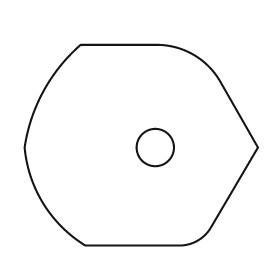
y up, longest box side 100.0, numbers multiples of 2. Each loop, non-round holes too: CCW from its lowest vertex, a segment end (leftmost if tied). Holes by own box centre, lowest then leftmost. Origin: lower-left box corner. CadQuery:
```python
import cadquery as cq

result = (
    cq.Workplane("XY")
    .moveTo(26.0, 0.0)
    .lineTo(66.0, 0.0)
    .threePointArc((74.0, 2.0), (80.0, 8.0))
    .lineTo(100.0, 42.0)
    .lineTo(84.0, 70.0)
    .threePointArc((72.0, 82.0), (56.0, 86.0))
    .lineTo(24.0, 86.0)
    .threePointArc((8.0, 66.0), (0.0, 42.0))
    .threePointArc((8.0, 18.0), (26.0, 0.0))
    .close()
    .moveTo(56.0, 42.0)
    .circle(8.0)
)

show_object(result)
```